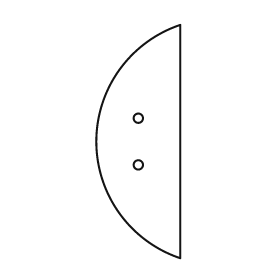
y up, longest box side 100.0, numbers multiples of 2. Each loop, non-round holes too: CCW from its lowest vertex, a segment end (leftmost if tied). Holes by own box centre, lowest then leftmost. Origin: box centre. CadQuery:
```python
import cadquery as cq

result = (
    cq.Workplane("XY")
    .moveTo(18.0, -50.0)
    .lineTo(18.0, 50.0)
    .threePointArc((-18.0, 0.0), (18.0, -50.0))
    .close()
    .moveTo(0.0, -10.0)
    .circle(2.0)
    .moveTo(0.0, 10.0)
    .circle(2.0)
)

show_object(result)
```